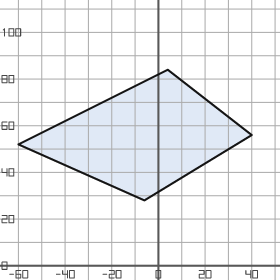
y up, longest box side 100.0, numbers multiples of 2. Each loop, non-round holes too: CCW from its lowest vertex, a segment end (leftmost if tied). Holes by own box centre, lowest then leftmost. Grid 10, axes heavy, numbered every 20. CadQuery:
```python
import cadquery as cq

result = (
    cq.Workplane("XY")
    .moveTo(-6.0, 28.0)
    .lineTo(40.0, 56.0)
    .lineTo(4.0, 84.0)
    .lineTo(-60.0, 52.0)
    .close()
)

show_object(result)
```